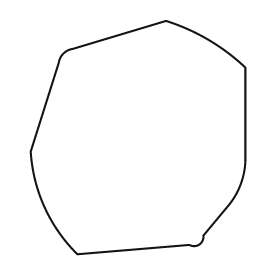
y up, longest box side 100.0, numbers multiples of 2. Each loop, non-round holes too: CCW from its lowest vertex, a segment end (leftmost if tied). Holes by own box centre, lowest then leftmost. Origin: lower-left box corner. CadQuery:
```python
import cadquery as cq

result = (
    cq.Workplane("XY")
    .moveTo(20.0, 0.0)
    .lineTo(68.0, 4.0)
    .threePointArc((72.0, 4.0), (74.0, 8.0))
    .lineTo(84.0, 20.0)
    .threePointArc((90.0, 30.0), (92.0, 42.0))
    .lineTo(92.0, 80.0)
    .threePointArc((76.0, 92.0), (58.0, 100.0))
    .lineTo(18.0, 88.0)
    .threePointArc((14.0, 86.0), (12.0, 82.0))
    .lineTo(0.0, 44.0)
    .threePointArc((6.0, 20.0), (20.0, 0.0))
    .close()
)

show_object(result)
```